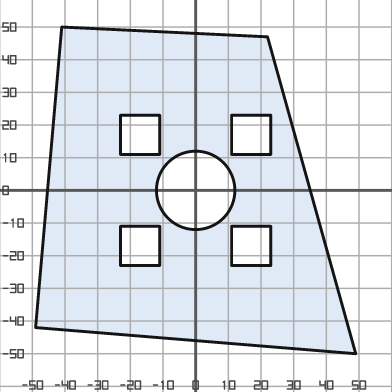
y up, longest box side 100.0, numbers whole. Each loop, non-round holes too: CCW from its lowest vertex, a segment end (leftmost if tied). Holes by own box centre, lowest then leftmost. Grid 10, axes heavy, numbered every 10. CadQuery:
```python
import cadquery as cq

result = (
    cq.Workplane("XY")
    .moveTo(49.0, -50.0)
    .lineTo(22.0, 47.0)
    .lineTo(-41.0, 50.0)
    .lineTo(-49.0, -42.0)
    .close()
    .moveTo(-23.0, -23.0)
    .lineTo(-11.0, -23.0)
    .lineTo(-11.0, -11.0)
    .lineTo(-23.0, -11.0)
    .close()
    .moveTo(11.0, -23.0)
    .lineTo(23.0, -23.0)
    .lineTo(23.0, -11.0)
    .lineTo(11.0, -11.0)
    .close()
    .moveTo(0.0, 0.0)
    .circle(12.0)
    .moveTo(-23.0, 11.0)
    .lineTo(-11.0, 11.0)
    .lineTo(-11.0, 23.0)
    .lineTo(-23.0, 23.0)
    .close()
    .moveTo(11.0, 11.0)
    .lineTo(23.0, 11.0)
    .lineTo(23.0, 23.0)
    .lineTo(11.0, 23.0)
    .close()
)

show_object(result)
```